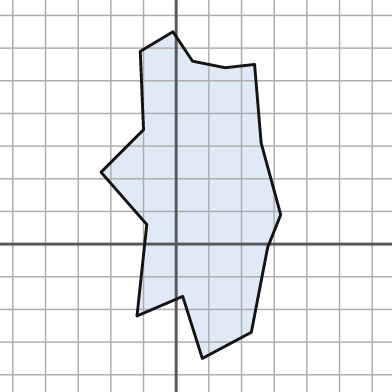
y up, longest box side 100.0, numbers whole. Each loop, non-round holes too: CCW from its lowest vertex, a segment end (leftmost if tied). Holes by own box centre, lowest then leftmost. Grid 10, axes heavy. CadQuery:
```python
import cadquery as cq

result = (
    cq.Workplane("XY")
    .moveTo(8.0, -35.0)
    .lineTo(23.0, -27.0)
    .lineTo(28.0, -1.0)
    .lineTo(32.0, 9.0)
    .lineTo(26.0, 31.0)
    .lineTo(24.0, 55.0)
    .lineTo(15.0, 54.0)
    .lineTo(5.0, 56.0)
    .lineTo(-1.0, 65.0)
    .lineTo(-11.0, 59.0)
    .lineTo(-10.0, 35.0)
    .lineTo(-23.0, 22.0)
    .lineTo(-9.0, 6.0)
    .lineTo(-12.0, -22.0)
    .lineTo(2.0, -16.0)
    .close()
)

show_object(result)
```